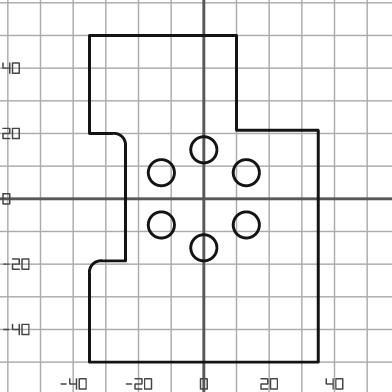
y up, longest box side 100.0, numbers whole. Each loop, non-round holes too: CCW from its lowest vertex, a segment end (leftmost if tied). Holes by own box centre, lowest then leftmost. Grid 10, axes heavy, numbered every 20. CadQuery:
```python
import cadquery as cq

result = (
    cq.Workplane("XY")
    .moveTo(-35.0, -50.0)
    .lineTo(35.0, -50.0)
    .lineTo(35.0, 21.0)
    .lineTo(10.0, 21.0)
    .lineTo(10.0, 50.0)
    .lineTo(-35.0, 50.0)
    .lineTo(-35.0, 20.0)
    .lineTo(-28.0, 20.0)
    .threePointArc((-25.0, 19.0), (-24.0, 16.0))
    .lineTo(-24.0, -19.0)
    .lineTo(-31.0, -19.0)
    .threePointArc((-34.0, -20.0), (-35.0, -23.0))
    .close()
    .moveTo(0.0, -15.0)
    .circle(4.0)
    .moveTo(-13.0, -8.0)
    .circle(4.0)
    .moveTo(13.0, -8.0)
    .circle(4.0)
    .moveTo(-13.0, 8.0)
    .circle(4.0)
    .moveTo(13.0, 8.0)
    .circle(4.0)
    .moveTo(0.0, 15.0)
    .circle(4.0)
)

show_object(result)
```